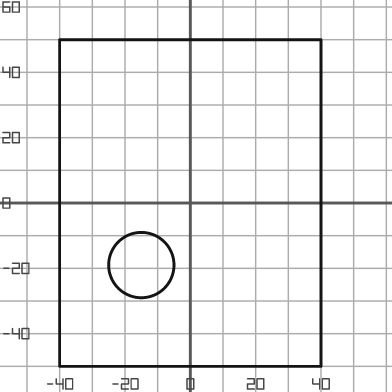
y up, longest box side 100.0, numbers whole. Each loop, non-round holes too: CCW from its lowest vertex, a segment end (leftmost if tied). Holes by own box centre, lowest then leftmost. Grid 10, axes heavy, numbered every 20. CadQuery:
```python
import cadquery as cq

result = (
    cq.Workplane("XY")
    .moveTo(-40.0, -50.0)
    .lineTo(40.0, -50.0)
    .lineTo(40.0, 50.0)
    .lineTo(-40.0, 50.0)
    .close()
    .moveTo(-15.0, -19.0)
    .circle(10.0)
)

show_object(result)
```